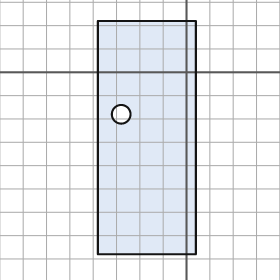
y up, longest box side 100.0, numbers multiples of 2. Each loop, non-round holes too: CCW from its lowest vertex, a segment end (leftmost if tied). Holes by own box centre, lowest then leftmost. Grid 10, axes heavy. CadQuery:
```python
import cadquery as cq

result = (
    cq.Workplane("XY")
    .moveTo(-38.0, -78.0)
    .lineTo(4.0, -78.0)
    .lineTo(4.0, 22.0)
    .lineTo(-38.0, 22.0)
    .close()
    .moveTo(-28.0, -18.0)
    .circle(4.0)
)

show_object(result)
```